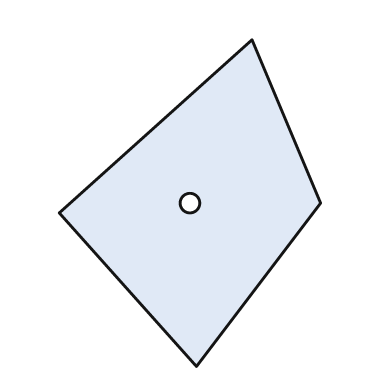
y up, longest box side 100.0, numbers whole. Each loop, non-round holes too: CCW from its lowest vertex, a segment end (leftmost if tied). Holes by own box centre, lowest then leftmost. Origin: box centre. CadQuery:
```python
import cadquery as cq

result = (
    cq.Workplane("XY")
    .moveTo(2.0, -50.0)
    .lineTo(40.0, 0.0)
    .lineTo(19.0, 50.0)
    .lineTo(-40.0, -3.0)
    .close()
    .moveTo(0.0, 0.0)
    .circle(3.0)
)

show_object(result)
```